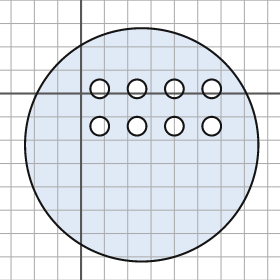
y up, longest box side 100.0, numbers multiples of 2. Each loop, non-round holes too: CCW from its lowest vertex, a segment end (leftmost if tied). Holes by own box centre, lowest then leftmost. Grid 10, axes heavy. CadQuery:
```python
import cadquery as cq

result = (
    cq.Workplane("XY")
    .moveTo(26.0, -22.0)
    .circle(50.0)
    .moveTo(8.0, -14.0)
    .circle(4.0)
    .moveTo(24.0, -14.0)
    .circle(4.0)
    .moveTo(40.0, -14.0)
    .circle(4.0)
    .moveTo(56.0, -14.0)
    .circle(4.0)
    .moveTo(8.0, 2.0)
    .circle(4.0)
    .moveTo(24.0, 2.0)
    .circle(4.0)
    .moveTo(40.0, 2.0)
    .circle(4.0)
    .moveTo(56.0, 2.0)
    .circle(4.0)
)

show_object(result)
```